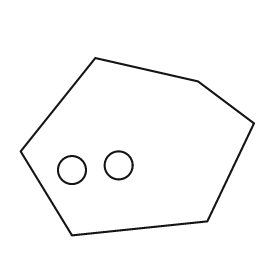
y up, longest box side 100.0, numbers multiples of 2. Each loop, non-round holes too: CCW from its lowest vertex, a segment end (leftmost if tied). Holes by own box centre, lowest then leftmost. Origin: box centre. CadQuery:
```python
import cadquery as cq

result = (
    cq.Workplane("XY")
    .moveTo(-28.0, -38.0)
    .lineTo(30.0, -32.0)
    .lineTo(50.0, 10.0)
    .lineTo(26.0, 28.0)
    .lineTo(-18.0, 38.0)
    .lineTo(-50.0, -2.0)
    .close()
    .moveTo(-28.0, -10.0)
    .circle(6.0)
    .moveTo(-8.0, -8.0)
    .circle(6.0)
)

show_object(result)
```